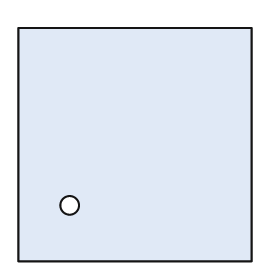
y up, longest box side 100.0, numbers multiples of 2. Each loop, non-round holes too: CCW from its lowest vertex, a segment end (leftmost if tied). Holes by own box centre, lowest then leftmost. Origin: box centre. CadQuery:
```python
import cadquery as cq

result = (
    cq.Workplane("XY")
    .moveTo(-50.0, -50.0)
    .lineTo(50.0, -50.0)
    .lineTo(50.0, 50.0)
    .lineTo(-50.0, 50.0)
    .close()
    .moveTo(-28.0, -26.0)
    .circle(4.0)
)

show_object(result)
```